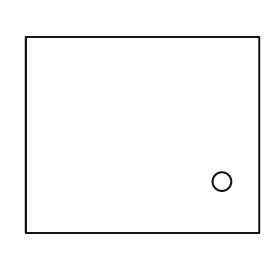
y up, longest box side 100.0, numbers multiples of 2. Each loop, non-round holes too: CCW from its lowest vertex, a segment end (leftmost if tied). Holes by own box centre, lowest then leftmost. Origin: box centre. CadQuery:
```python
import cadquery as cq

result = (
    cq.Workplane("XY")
    .moveTo(-50.0, -42.0)
    .lineTo(50.0, -42.0)
    .lineTo(50.0, 42.0)
    .lineTo(-50.0, 42.0)
    .close()
    .moveTo(34.0, -20.0)
    .circle(4.0)
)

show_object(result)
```